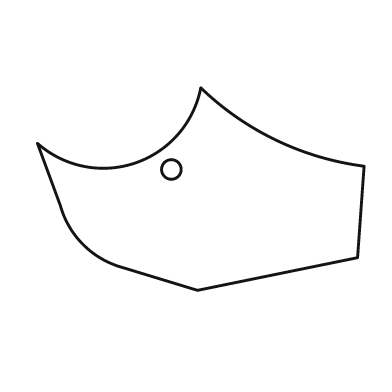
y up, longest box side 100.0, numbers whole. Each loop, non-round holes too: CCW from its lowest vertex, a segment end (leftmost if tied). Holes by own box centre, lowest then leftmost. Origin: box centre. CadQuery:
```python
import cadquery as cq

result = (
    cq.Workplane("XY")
    .moveTo(-1.0, -31.0)
    .lineTo(48.0, -21.0)
    .lineTo(50.0, 7.0)
    .threePointArc((23.0, 15.0), (0.0, 31.0))
    .threePointArc((-20.0, 8.0), (-50.0, 14.0))
    .lineTo(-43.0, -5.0)
    .threePointArc((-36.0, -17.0), (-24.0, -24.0))
    .close()
    .moveTo(-9.0, 6.0)
    .circle(3.0)
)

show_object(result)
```